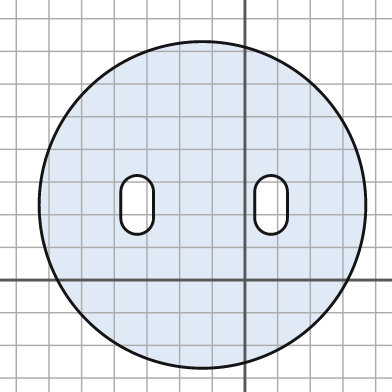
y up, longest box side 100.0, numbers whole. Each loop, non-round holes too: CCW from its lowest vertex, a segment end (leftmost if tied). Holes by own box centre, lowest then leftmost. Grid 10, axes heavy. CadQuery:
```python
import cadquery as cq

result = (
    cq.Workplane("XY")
    .moveTo(-13.0, 23.0)
    .circle(50.0)
    .moveTo(-38.0, 19.0)
    .threePointArc((-33.0, 14.0), (-28.0, 19.0))
    .lineTo(-28.0, 27.0)
    .threePointArc((-33.0, 32.0), (-38.0, 27.0))
    .close()
    .moveTo(3.0, 19.0)
    .threePointArc((8.0, 14.0), (13.0, 19.0))
    .lineTo(13.0, 27.0)
    .threePointArc((8.0, 32.0), (3.0, 27.0))
    .close()
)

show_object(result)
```